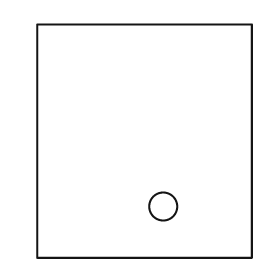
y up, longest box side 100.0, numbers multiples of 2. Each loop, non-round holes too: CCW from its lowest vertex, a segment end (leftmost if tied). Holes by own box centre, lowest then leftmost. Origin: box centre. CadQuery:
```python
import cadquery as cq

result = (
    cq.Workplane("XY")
    .moveTo(-46.0, -50.0)
    .lineTo(46.0, -50.0)
    .lineTo(46.0, 50.0)
    .lineTo(-46.0, 50.0)
    .close()
    .moveTo(8.0, -28.0)
    .circle(6.0)
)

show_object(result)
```